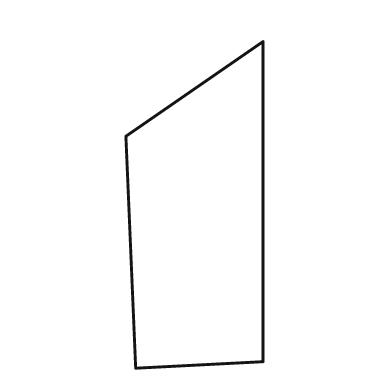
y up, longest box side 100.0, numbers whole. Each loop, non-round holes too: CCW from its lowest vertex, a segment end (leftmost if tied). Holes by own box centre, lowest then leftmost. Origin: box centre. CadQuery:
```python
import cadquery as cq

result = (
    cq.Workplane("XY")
    .moveTo(-18.0, -50.0)
    .lineTo(21.0, -48.0)
    .lineTo(21.0, 50.0)
    .lineTo(-21.0, 21.0)
    .close()
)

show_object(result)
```